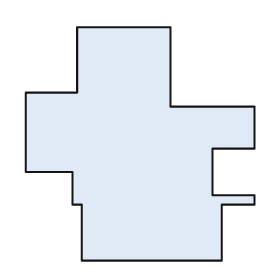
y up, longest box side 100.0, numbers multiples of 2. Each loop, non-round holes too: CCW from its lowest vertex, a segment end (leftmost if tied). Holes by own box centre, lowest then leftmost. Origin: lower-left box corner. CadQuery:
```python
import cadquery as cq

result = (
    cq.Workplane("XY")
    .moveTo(24.0, 0.0)
    .lineTo(84.0, 0.0)
    .lineTo(84.0, 24.0)
    .lineTo(98.0, 24.0)
    .lineTo(98.0, 28.0)
    .lineTo(80.0, 28.0)
    .lineTo(80.0, 48.0)
    .lineTo(98.0, 48.0)
    .lineTo(98.0, 66.0)
    .lineTo(62.0, 66.0)
    .lineTo(62.0, 100.0)
    .lineTo(22.0, 100.0)
    .lineTo(22.0, 72.0)
    .lineTo(0.0, 72.0)
    .lineTo(0.0, 38.0)
    .lineTo(20.0, 38.0)
    .lineTo(20.0, 24.0)
    .lineTo(24.0, 24.0)
    .close()
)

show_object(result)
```